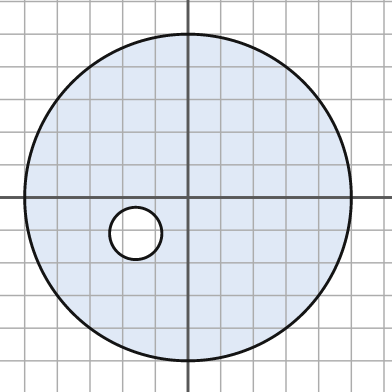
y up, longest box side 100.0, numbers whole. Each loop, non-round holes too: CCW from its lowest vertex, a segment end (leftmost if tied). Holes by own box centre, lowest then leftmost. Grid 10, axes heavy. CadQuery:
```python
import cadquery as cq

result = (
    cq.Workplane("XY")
    .moveTo(0.0, 0.0)
    .circle(50.0)
    .moveTo(-16.0, -11.0)
    .circle(8.0)
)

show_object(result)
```